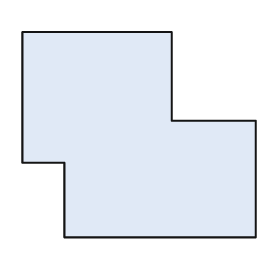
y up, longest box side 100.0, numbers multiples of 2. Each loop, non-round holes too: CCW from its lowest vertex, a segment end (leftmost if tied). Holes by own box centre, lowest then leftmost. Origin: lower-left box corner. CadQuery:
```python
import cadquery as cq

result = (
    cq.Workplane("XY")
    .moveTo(18.0, 0.0)
    .lineTo(100.0, 0.0)
    .lineTo(100.0, 50.0)
    .lineTo(64.0, 50.0)
    .lineTo(64.0, 88.0)
    .lineTo(0.0, 88.0)
    .lineTo(0.0, 32.0)
    .lineTo(18.0, 32.0)
    .close()
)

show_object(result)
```